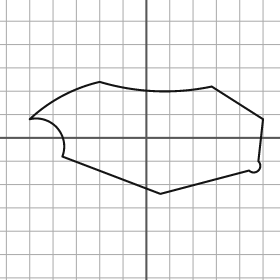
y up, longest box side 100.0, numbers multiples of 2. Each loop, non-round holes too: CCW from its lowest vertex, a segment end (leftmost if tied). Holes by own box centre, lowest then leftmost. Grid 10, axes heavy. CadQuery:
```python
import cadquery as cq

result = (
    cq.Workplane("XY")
    .moveTo(6.0, -24.0)
    .lineTo(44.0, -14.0)
    .threePointArc((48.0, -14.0), (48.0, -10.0))
    .lineTo(50.0, 8.0)
    .lineTo(28.0, 22.0)
    .threePointArc((4.0, 20.0), (-20.0, 24.0))
    .threePointArc((-36.0, 18.0), (-50.0, 8.0))
    .threePointArc((-38.0, 4.0), (-36.0, -8.0))
    .close()
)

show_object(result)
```